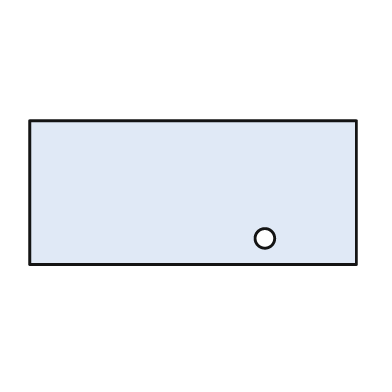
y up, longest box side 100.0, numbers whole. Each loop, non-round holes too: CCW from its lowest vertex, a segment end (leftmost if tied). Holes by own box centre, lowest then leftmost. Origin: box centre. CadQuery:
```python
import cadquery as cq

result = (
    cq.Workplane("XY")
    .moveTo(-50.0, -22.0)
    .lineTo(50.0, -22.0)
    .lineTo(50.0, 22.0)
    .lineTo(-50.0, 22.0)
    .close()
    .moveTo(22.0, -14.0)
    .circle(3.0)
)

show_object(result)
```